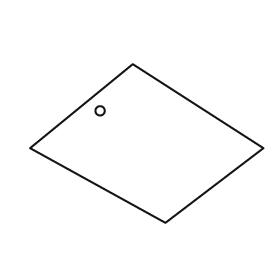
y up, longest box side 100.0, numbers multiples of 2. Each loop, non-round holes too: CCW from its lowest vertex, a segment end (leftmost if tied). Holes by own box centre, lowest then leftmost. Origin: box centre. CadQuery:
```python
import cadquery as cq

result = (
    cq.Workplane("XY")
    .moveTo(8.0, -34.0)
    .lineTo(50.0, -2.0)
    .lineTo(-6.0, 34.0)
    .lineTo(-50.0, -2.0)
    .close()
    .moveTo(-20.0, 14.0)
    .circle(2.0)
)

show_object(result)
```